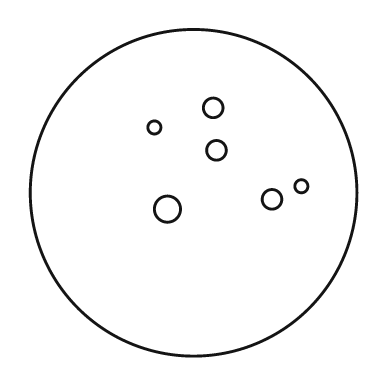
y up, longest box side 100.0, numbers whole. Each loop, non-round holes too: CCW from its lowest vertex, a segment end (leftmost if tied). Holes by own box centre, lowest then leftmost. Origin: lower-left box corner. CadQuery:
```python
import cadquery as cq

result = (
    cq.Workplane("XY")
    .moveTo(50.0, 50.0)
    .circle(50.0)
    .moveTo(42.0, 45.0)
    .circle(4.0)
    .moveTo(74.0, 48.0)
    .circle(3.0)
    .moveTo(83.0, 52.0)
    .circle(2.0)
    .moveTo(57.0, 63.0)
    .circle(3.0)
    .moveTo(38.0, 70.0)
    .circle(2.0)
    .moveTo(56.0, 76.0)
    .circle(3.0)
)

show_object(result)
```